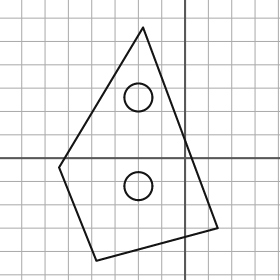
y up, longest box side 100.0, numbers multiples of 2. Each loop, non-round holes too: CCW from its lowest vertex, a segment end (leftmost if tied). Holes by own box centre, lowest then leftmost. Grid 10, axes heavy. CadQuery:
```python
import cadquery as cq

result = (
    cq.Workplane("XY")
    .moveTo(-38.0, -44.0)
    .lineTo(14.0, -30.0)
    .lineTo(-18.0, 56.0)
    .lineTo(-54.0, -4.0)
    .close()
    .moveTo(-20.0, -12.0)
    .circle(6.0)
    .moveTo(-20.0, 26.0)
    .circle(6.0)
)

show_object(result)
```